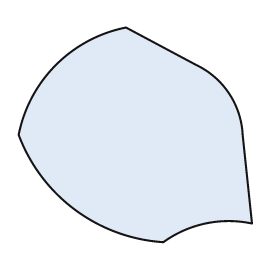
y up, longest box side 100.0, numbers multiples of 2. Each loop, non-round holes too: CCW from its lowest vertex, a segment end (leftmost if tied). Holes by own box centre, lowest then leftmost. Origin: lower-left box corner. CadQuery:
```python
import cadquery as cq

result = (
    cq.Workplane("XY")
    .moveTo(62.0, 0.0)
    .threePointArc((80.0, 8.0), (100.0, 8.0))
    .lineTo(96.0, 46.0)
    .threePointArc((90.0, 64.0), (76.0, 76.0))
    .lineTo(46.0, 92.0)
    .threePointArc((16.0, 76.0), (0.0, 46.0))
    .threePointArc((24.0, 14.0), (62.0, 0.0))
    .close()
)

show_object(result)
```